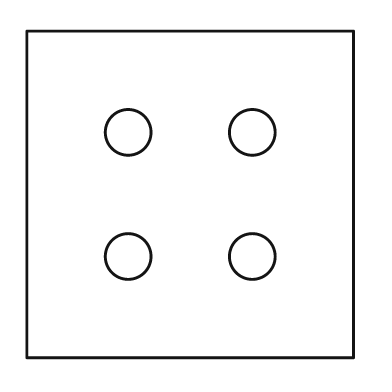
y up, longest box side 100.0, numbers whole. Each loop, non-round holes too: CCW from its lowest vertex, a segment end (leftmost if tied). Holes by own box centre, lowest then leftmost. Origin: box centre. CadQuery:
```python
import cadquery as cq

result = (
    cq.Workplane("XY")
    .moveTo(-50.0, -50.0)
    .lineTo(50.0, -50.0)
    .lineTo(50.0, 50.0)
    .lineTo(-50.0, 50.0)
    .close()
    .moveTo(-19.0, -19.0)
    .circle(7.0)
    .moveTo(19.0, -19.0)
    .circle(7.0)
    .moveTo(-19.0, 19.0)
    .circle(7.0)
    .moveTo(19.0, 19.0)
    .circle(7.0)
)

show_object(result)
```